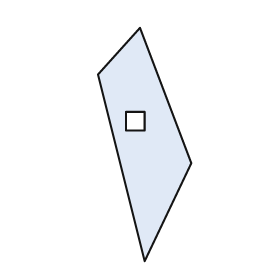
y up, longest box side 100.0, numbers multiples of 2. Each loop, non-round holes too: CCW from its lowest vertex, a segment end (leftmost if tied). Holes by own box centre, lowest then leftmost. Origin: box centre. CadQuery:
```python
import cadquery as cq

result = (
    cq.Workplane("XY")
    .moveTo(0.0, -50.0)
    .lineTo(20.0, -8.0)
    .lineTo(-2.0, 50.0)
    .lineTo(-20.0, 30.0)
    .close()
    .moveTo(-8.0, 6.0)
    .lineTo(0.0, 6.0)
    .lineTo(0.0, 14.0)
    .lineTo(-8.0, 14.0)
    .close()
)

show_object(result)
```